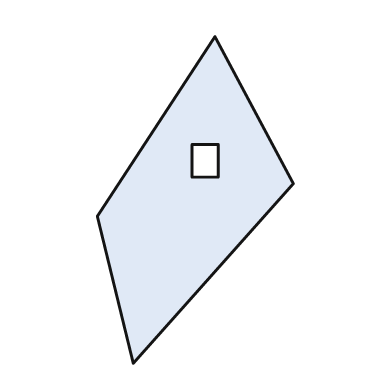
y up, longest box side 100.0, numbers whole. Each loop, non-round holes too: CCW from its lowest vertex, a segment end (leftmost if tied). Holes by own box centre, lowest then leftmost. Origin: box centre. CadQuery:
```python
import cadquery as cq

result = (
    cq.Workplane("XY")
    .moveTo(-19.0, -50.0)
    .lineTo(30.0, 5.0)
    .lineTo(6.0, 50.0)
    .lineTo(-30.0, -5.0)
    .close()
    .moveTo(-1.0, 7.0)
    .lineTo(7.0, 7.0)
    .lineTo(7.0, 17.0)
    .lineTo(-1.0, 17.0)
    .close()
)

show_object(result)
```